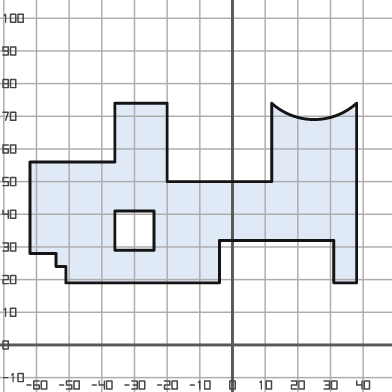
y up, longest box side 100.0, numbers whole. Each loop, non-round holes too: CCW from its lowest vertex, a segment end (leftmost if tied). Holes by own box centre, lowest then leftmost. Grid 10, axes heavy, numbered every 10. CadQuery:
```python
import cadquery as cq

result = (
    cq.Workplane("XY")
    .moveTo(-51.0, 19.0)
    .lineTo(-4.0, 19.0)
    .lineTo(-4.0, 32.0)
    .lineTo(31.0, 32.0)
    .lineTo(31.0, 19.0)
    .lineTo(38.0, 19.0)
    .lineTo(38.0, 74.0)
    .threePointArc((25.0, 69.0), (12.0, 74.0))
    .lineTo(12.0, 50.0)
    .lineTo(-20.0, 50.0)
    .lineTo(-20.0, 74.0)
    .lineTo(-36.0, 74.0)
    .lineTo(-36.0, 56.0)
    .lineTo(-62.0, 56.0)
    .lineTo(-62.0, 28.0)
    .lineTo(-54.0, 28.0)
    .lineTo(-54.0, 24.0)
    .lineTo(-51.0, 24.0)
    .close()
    .moveTo(-36.0, 29.0)
    .lineTo(-24.0, 29.0)
    .lineTo(-24.0, 41.0)
    .lineTo(-36.0, 41.0)
    .close()
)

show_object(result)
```